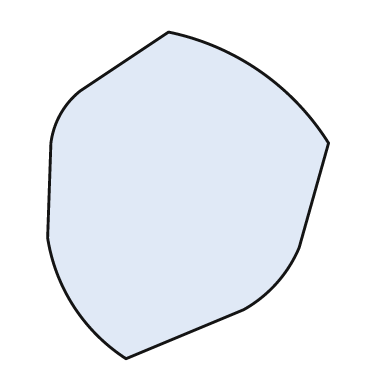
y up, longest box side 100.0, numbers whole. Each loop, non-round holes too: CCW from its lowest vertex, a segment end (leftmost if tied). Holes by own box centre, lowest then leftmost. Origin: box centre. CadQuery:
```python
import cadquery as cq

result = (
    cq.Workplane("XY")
    .moveTo(-19.0, -50.0)
    .lineTo(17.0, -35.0)
    .threePointArc((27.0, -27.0), (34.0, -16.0))
    .lineTo(43.0, 16.0)
    .threePointArc((22.0, 38.0), (-6.0, 50.0))
    .lineTo(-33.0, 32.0)
    .threePointArc((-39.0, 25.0), (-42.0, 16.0))
    .lineTo(-43.0, -13.0)
    .threePointArc((-35.0, -34.0), (-19.0, -50.0))
    .close()
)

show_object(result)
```